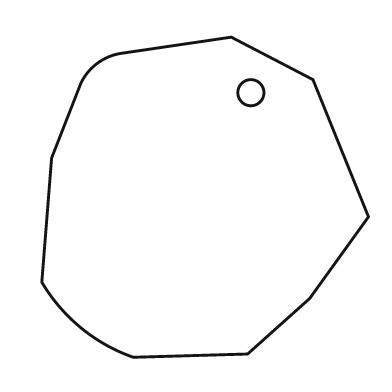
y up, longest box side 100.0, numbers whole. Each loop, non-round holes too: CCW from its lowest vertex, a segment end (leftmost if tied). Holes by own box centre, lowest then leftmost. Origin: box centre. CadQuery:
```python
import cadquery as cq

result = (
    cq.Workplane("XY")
    .moveTo(-22.0, -49.0)
    .lineTo(13.0, -48.0)
    .lineTo(32.0, -31.0)
    .lineTo(50.0, -6.0)
    .lineTo(33.0, 36.0)
    .lineTo(8.0, 49.0)
    .lineTo(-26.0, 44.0)
    .threePointArc((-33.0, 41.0), (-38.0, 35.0))
    .lineTo(-47.0, 12.0)
    .lineTo(-50.0, -26.0)
    .threePointArc((-38.0, -40.0), (-22.0, -49.0))
    .close()
    .moveTo(14.0, 32.0)
    .circle(4.0)
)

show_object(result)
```